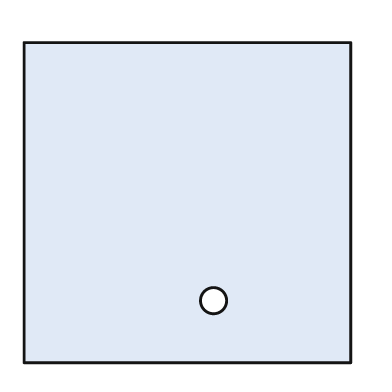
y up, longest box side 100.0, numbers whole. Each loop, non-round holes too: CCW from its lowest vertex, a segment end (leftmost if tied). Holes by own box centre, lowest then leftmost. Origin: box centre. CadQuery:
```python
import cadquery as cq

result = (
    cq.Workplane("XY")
    .moveTo(-50.0, -49.0)
    .lineTo(50.0, -49.0)
    .lineTo(50.0, 49.0)
    .lineTo(-50.0, 49.0)
    .close()
    .moveTo(8.0, -30.0)
    .circle(4.0)
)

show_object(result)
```